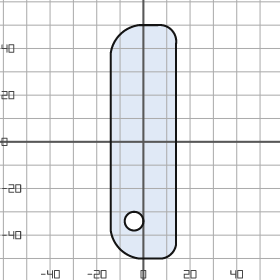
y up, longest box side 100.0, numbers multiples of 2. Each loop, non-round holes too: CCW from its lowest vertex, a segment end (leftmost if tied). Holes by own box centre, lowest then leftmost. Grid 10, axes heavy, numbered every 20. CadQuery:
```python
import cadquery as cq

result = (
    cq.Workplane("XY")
    .moveTo(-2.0, -50.0)
    .lineTo(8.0, -50.0)
    .threePointArc((12.0, -48.0), (14.0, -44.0))
    .lineTo(14.0, 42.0)
    .threePointArc((12.0, 48.0), (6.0, 50.0))
    .lineTo(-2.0, 50.0)
    .threePointArc((-10.0, 46.0), (-14.0, 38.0))
    .lineTo(-14.0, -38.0)
    .threePointArc((-10.0, -46.0), (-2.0, -50.0))
    .close()
    .moveTo(-4.0, -34.0)
    .circle(4.0)
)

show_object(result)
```